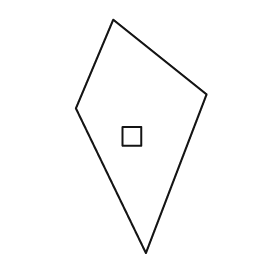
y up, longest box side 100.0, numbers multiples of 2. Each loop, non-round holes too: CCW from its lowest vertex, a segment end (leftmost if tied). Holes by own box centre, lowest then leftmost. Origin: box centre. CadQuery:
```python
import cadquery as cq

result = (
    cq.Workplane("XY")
    .moveTo(2.0, -50.0)
    .lineTo(28.0, 18.0)
    .lineTo(-12.0, 50.0)
    .lineTo(-28.0, 12.0)
    .close()
    .moveTo(-8.0, -4.0)
    .lineTo(0.0, -4.0)
    .lineTo(0.0, 4.0)
    .lineTo(-8.0, 4.0)
    .close()
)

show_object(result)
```